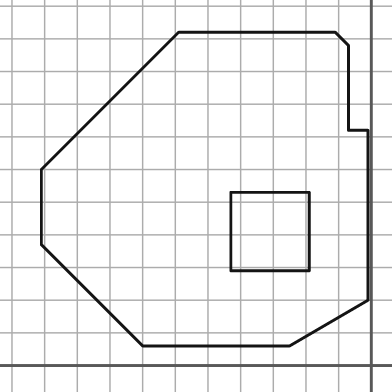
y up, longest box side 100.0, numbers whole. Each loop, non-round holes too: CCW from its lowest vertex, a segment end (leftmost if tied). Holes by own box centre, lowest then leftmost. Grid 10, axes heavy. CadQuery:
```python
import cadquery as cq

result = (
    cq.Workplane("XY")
    .moveTo(-70.0, 6.0)
    .lineTo(-25.0, 6.0)
    .lineTo(-1.0, 20.0)
    .lineTo(-1.0, 72.0)
    .lineTo(-7.0, 72.0)
    .lineTo(-7.0, 98.0)
    .lineTo(-11.0, 102.0)
    .lineTo(-59.0, 102.0)
    .lineTo(-101.0, 60.0)
    .lineTo(-101.0, 37.0)
    .close()
    .moveTo(-43.0, 29.0)
    .lineTo(-19.0, 29.0)
    .lineTo(-19.0, 53.0)
    .lineTo(-43.0, 53.0)
    .close()
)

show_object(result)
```